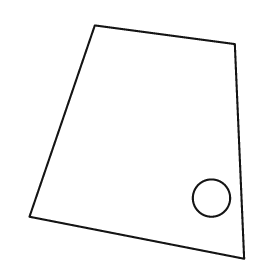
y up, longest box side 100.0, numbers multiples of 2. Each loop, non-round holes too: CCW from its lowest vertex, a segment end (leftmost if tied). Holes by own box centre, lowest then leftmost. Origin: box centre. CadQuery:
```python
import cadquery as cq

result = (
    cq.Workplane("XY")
    .moveTo(46.0, -50.0)
    .lineTo(42.0, 42.0)
    .lineTo(-18.0, 50.0)
    .lineTo(-46.0, -32.0)
    .close()
    .moveTo(32.0, -24.0)
    .circle(8.0)
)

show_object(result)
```